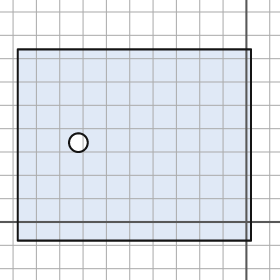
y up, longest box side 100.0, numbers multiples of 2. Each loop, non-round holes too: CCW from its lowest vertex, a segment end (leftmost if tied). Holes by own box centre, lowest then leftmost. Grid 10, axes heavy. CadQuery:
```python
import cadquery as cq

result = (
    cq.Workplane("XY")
    .moveTo(-98.0, -8.0)
    .lineTo(2.0, -8.0)
    .lineTo(2.0, 74.0)
    .lineTo(-98.0, 74.0)
    .close()
    .moveTo(-72.0, 34.0)
    .circle(4.0)
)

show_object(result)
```